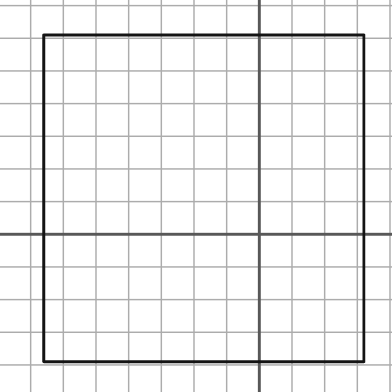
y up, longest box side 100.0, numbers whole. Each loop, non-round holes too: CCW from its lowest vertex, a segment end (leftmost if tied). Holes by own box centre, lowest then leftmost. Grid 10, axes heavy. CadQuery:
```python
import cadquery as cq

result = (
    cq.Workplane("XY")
    .moveTo(-66.0, -39.0)
    .lineTo(32.0, -39.0)
    .lineTo(32.0, 61.0)
    .lineTo(-66.0, 61.0)
    .close()
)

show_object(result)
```